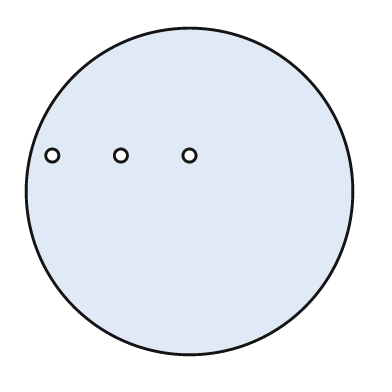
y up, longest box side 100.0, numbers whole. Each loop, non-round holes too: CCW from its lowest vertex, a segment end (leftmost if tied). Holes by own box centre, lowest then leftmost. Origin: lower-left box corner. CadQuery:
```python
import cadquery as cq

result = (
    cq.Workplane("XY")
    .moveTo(50.0, 50.0)
    .circle(50.0)
    .moveTo(8.0, 61.0)
    .circle(2.0)
    .moveTo(29.0, 61.0)
    .circle(2.0)
    .moveTo(50.0, 61.0)
    .circle(2.0)
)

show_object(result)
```